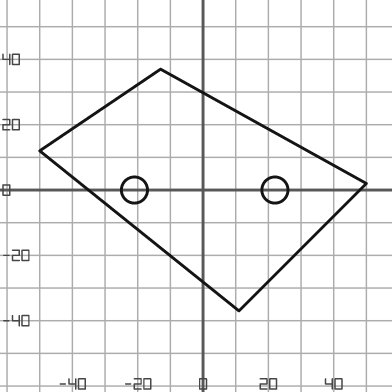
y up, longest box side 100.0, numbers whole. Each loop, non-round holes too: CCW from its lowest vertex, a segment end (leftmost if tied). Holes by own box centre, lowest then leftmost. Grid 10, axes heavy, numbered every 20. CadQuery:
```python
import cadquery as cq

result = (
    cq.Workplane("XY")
    .moveTo(11.0, -37.0)
    .lineTo(50.0, 2.0)
    .lineTo(-13.0, 37.0)
    .lineTo(-50.0, 12.0)
    .close()
    .moveTo(-21.0, 0.0)
    .circle(4.0)
    .moveTo(22.0, 0.0)
    .circle(4.0)
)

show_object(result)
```